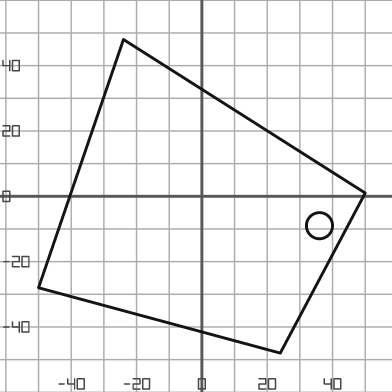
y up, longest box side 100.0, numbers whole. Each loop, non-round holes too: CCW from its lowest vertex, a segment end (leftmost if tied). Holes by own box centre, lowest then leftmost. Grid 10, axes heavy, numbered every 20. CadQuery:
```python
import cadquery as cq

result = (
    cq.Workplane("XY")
    .moveTo(24.0, -48.0)
    .lineTo(50.0, 1.0)
    .lineTo(-24.0, 48.0)
    .lineTo(-50.0, -28.0)
    .close()
    .moveTo(36.0, -9.0)
    .circle(4.0)
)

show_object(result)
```